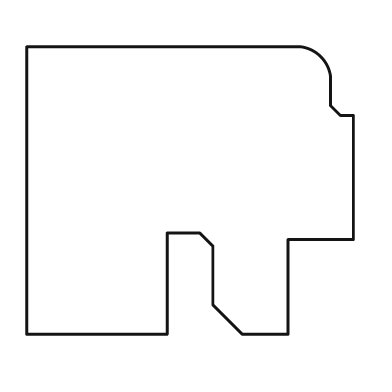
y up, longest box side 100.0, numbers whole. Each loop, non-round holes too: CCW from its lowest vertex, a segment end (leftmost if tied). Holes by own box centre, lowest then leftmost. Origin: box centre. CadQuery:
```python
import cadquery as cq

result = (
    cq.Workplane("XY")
    .moveTo(-50.0, -44.0)
    .lineTo(-7.0, -44.0)
    .lineTo(-7.0, -13.0)
    .lineTo(3.0, -13.0)
    .lineTo(7.0, -17.0)
    .lineTo(7.0, -35.0)
    .lineTo(16.0, -44.0)
    .lineTo(30.0, -44.0)
    .lineTo(30.0, -15.0)
    .lineTo(50.0, -15.0)
    .lineTo(50.0, 23.0)
    .lineTo(46.0, 23.0)
    .lineTo(43.0, 26.0)
    .lineTo(43.0, 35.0)
    .threePointArc((40.0, 41.0), (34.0, 44.0))
    .lineTo(-50.0, 44.0)
    .close()
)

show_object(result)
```